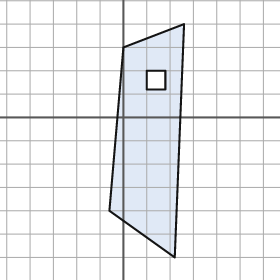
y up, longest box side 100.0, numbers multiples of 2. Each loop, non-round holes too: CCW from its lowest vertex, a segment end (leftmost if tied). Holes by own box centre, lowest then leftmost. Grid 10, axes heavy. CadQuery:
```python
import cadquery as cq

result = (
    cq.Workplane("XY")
    .moveTo(22.0, -60.0)
    .lineTo(26.0, 40.0)
    .lineTo(0.0, 30.0)
    .lineTo(-6.0, -40.0)
    .close()
    .moveTo(10.0, 12.0)
    .lineTo(18.0, 12.0)
    .lineTo(18.0, 20.0)
    .lineTo(10.0, 20.0)
    .close()
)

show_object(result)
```